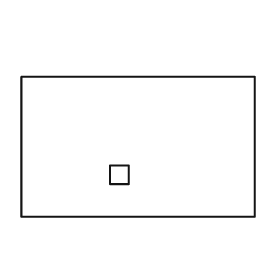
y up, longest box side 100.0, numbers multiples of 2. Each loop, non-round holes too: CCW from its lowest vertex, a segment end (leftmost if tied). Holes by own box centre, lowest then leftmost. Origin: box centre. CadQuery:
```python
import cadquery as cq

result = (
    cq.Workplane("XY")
    .moveTo(-50.0, -30.0)
    .lineTo(50.0, -30.0)
    .lineTo(50.0, 30.0)
    .lineTo(-50.0, 30.0)
    .close()
    .moveTo(-12.0, -16.0)
    .lineTo(-4.0, -16.0)
    .lineTo(-4.0, -8.0)
    .lineTo(-12.0, -8.0)
    .close()
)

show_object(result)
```